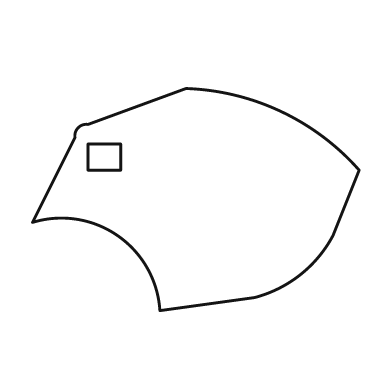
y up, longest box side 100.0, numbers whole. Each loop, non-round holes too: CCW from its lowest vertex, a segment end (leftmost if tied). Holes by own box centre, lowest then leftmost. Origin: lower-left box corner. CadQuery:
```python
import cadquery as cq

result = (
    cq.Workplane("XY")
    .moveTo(39.0, 0.0)
    .lineTo(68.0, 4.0)
    .threePointArc((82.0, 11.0), (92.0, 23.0))
    .lineTo(100.0, 43.0)
    .threePointArc((76.0, 61.0), (47.0, 68.0))
    .lineTo(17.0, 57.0)
    .threePointArc((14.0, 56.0), (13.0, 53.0))
    .lineTo(0.0, 27.0)
    .threePointArc((26.0, 23.0), (39.0, 0.0))
    .close()
    .moveTo(17.0, 43.0)
    .lineTo(27.0, 43.0)
    .lineTo(27.0, 51.0)
    .lineTo(17.0, 51.0)
    .close()
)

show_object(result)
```